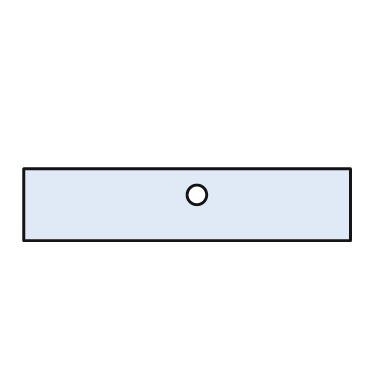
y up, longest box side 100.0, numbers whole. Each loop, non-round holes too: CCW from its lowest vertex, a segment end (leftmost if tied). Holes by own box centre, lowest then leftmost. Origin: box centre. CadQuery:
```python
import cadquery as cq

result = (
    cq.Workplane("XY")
    .moveTo(-50.0, -11.0)
    .lineTo(50.0, -11.0)
    .lineTo(50.0, 11.0)
    .lineTo(-50.0, 11.0)
    .close()
    .moveTo(3.0, 3.0)
    .circle(3.0)
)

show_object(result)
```